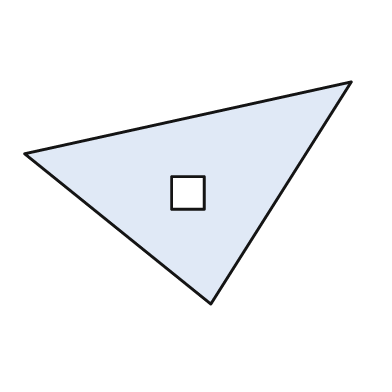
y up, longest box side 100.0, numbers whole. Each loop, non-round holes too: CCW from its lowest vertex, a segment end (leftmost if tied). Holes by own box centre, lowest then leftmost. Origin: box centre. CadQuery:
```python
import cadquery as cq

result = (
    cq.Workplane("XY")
    .moveTo(7.0, -34.0)
    .lineTo(50.0, 34.0)
    .lineTo(-50.0, 12.0)
    .close()
    .moveTo(-5.0, -5.0)
    .lineTo(5.0, -5.0)
    .lineTo(5.0, 5.0)
    .lineTo(-5.0, 5.0)
    .close()
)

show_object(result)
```